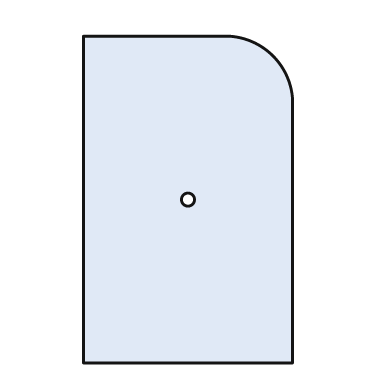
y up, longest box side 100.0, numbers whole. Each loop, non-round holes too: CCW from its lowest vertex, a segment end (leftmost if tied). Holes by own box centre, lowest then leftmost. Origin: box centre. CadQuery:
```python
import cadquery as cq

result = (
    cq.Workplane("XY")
    .moveTo(-32.0, -50.0)
    .lineTo(32.0, -50.0)
    .lineTo(32.0, 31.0)
    .threePointArc((26.0, 44.0), (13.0, 50.0))
    .lineTo(-32.0, 50.0)
    .close()
    .moveTo(0.0, 0.0)
    .circle(2.0)
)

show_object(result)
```